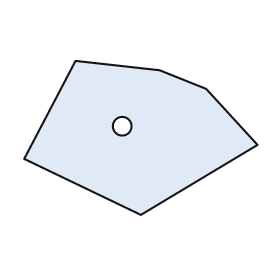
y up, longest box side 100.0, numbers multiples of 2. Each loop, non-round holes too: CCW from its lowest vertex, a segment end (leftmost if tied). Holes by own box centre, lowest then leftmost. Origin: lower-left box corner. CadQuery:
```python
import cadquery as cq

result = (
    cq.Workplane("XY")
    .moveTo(50.0, 0.0)
    .lineTo(100.0, 30.0)
    .lineTo(78.0, 54.0)
    .lineTo(58.0, 62.0)
    .lineTo(22.0, 66.0)
    .lineTo(0.0, 24.0)
    .close()
    .moveTo(42.0, 38.0)
    .circle(4.0)
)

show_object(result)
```